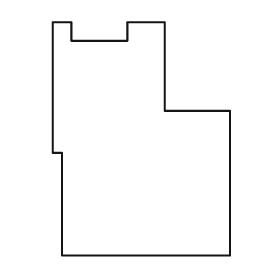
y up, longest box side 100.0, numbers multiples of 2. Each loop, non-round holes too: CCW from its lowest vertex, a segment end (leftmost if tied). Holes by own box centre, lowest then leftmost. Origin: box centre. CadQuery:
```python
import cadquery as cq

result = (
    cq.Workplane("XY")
    .moveTo(-34.0, -50.0)
    .lineTo(38.0, -50.0)
    .lineTo(38.0, 12.0)
    .lineTo(10.0, 12.0)
    .lineTo(10.0, 50.0)
    .lineTo(-6.0, 50.0)
    .lineTo(-6.0, 42.0)
    .lineTo(-30.0, 42.0)
    .lineTo(-30.0, 50.0)
    .lineTo(-38.0, 50.0)
    .lineTo(-38.0, -6.0)
    .lineTo(-34.0, -6.0)
    .close()
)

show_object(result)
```